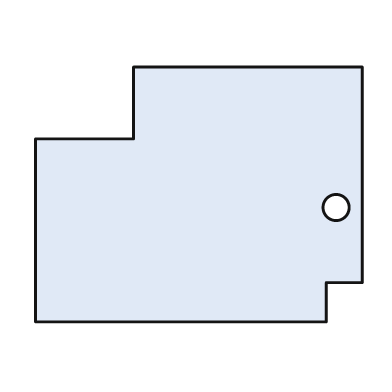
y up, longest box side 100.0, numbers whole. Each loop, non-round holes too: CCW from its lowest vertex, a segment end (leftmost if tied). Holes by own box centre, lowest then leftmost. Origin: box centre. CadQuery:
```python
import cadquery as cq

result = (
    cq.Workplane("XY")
    .moveTo(-50.0, -39.0)
    .lineTo(39.0, -39.0)
    .lineTo(39.0, -27.0)
    .lineTo(50.0, -27.0)
    .lineTo(50.0, 39.0)
    .lineTo(-20.0, 39.0)
    .lineTo(-20.0, 17.0)
    .lineTo(-50.0, 17.0)
    .close()
    .moveTo(42.0, -4.0)
    .circle(4.0)
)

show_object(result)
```